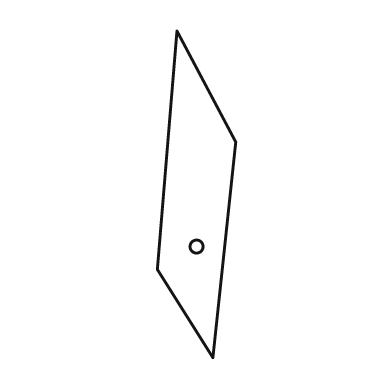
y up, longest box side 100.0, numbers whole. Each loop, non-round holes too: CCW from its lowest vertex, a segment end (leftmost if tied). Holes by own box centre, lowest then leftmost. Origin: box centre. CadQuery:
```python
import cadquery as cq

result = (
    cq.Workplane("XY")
    .moveTo(5.0, -50.0)
    .lineTo(12.0, 16.0)
    .lineTo(-6.0, 50.0)
    .lineTo(-12.0, -23.0)
    .close()
    .moveTo(0.0, -16.0)
    .circle(2.0)
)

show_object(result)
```